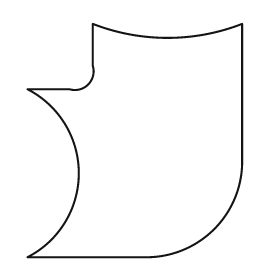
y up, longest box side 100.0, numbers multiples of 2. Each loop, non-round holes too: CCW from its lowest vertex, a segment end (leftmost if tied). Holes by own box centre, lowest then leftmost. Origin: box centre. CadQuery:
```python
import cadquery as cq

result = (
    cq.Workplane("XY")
    .moveTo(-46.0, -50.0)
    .lineTo(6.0, -50.0)
    .threePointArc((34.0, -38.0), (46.0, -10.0))
    .lineTo(46.0, 50.0)
    .threePointArc((14.0, 44.0), (-18.0, 50.0))
    .lineTo(-18.0, 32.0)
    .threePointArc((-20.0, 24.0), (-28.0, 22.0))
    .lineTo(-46.0, 22.0)
    .threePointArc((-24.0, -14.0), (-46.0, -50.0))
    .close()
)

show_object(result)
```